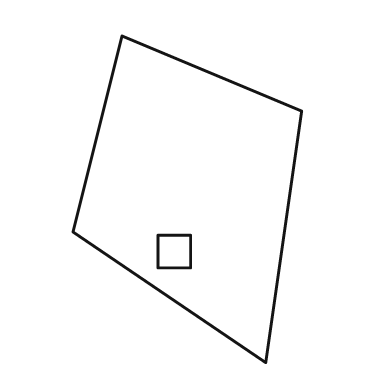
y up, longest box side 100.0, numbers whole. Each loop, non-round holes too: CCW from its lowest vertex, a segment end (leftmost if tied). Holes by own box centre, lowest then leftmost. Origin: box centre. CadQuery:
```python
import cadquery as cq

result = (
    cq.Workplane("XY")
    .moveTo(24.0, -50.0)
    .lineTo(35.0, 27.0)
    .lineTo(-20.0, 50.0)
    .lineTo(-35.0, -10.0)
    .close()
    .moveTo(-9.0, -21.0)
    .lineTo(1.0, -21.0)
    .lineTo(1.0, -11.0)
    .lineTo(-9.0, -11.0)
    .close()
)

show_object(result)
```